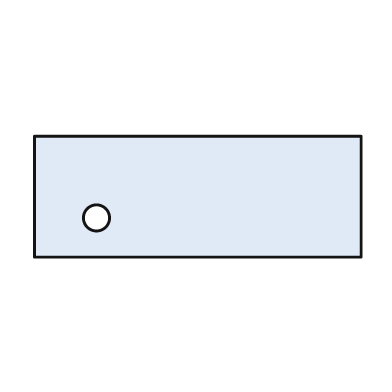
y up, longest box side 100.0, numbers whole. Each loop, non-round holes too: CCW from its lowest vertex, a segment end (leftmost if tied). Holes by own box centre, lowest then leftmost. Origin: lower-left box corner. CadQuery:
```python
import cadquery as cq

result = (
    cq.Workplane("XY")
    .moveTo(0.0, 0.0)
    .lineTo(100.0, 0.0)
    .lineTo(100.0, 37.0)
    .lineTo(0.0, 37.0)
    .close()
    .moveTo(19.0, 12.0)
    .circle(4.0)
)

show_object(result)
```